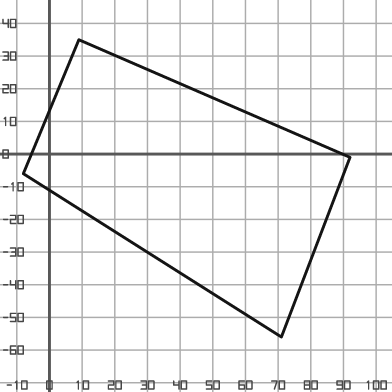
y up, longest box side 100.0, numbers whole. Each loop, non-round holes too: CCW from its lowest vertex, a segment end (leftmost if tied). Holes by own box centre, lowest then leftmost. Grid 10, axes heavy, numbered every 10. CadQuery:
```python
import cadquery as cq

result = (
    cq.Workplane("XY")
    .moveTo(71.0, -56.0)
    .lineTo(92.0, -1.0)
    .lineTo(9.0, 35.0)
    .lineTo(-8.0, -6.0)
    .close()
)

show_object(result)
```